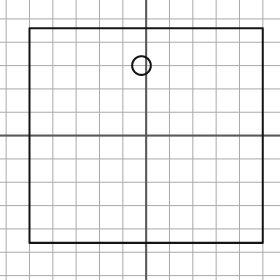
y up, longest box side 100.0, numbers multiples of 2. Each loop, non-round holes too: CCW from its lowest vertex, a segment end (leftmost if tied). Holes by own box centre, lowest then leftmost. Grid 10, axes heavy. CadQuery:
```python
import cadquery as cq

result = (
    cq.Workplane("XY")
    .moveTo(-50.0, -46.0)
    .lineTo(50.0, -46.0)
    .lineTo(50.0, 46.0)
    .lineTo(-50.0, 46.0)
    .close()
    .moveTo(-2.0, 30.0)
    .circle(4.0)
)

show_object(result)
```